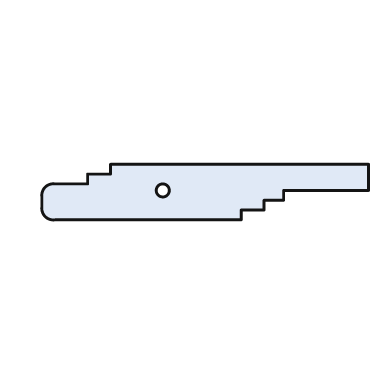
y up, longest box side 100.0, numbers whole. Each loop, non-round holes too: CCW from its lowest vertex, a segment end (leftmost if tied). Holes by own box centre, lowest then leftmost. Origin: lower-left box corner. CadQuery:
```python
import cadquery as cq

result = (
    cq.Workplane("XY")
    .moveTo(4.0, 0.0)
    .lineTo(61.0, 0.0)
    .lineTo(61.0, 3.0)
    .lineTo(68.0, 3.0)
    .lineTo(68.0, 6.0)
    .lineTo(74.0, 6.0)
    .lineTo(74.0, 9.0)
    .lineTo(100.0, 9.0)
    .lineTo(100.0, 17.0)
    .lineTo(21.0, 17.0)
    .lineTo(21.0, 14.0)
    .lineTo(14.0, 14.0)
    .lineTo(14.0, 11.0)
    .lineTo(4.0, 11.0)
    .threePointArc((1.0, 10.0), (0.0, 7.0))
    .lineTo(0.0, 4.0)
    .threePointArc((1.0, 1.0), (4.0, 0.0))
    .close()
    .moveTo(37.0, 9.0)
    .circle(2.0)
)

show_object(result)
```